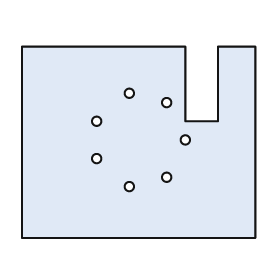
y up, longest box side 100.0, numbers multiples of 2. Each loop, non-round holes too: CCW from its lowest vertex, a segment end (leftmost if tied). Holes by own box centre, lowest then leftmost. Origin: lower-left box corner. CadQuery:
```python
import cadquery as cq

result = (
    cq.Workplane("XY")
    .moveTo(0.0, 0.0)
    .lineTo(100.0, 0.0)
    .lineTo(100.0, 82.0)
    .lineTo(84.0, 82.0)
    .lineTo(84.0, 50.0)
    .lineTo(70.0, 50.0)
    .lineTo(70.0, 82.0)
    .lineTo(0.0, 82.0)
    .close()
    .moveTo(46.0, 22.0)
    .circle(2.0)
    .moveTo(62.0, 26.0)
    .circle(2.0)
    .moveTo(32.0, 34.0)
    .circle(2.0)
    .moveTo(70.0, 42.0)
    .circle(2.0)
    .moveTo(32.0, 50.0)
    .circle(2.0)
    .moveTo(62.0, 58.0)
    .circle(2.0)
    .moveTo(46.0, 62.0)
    .circle(2.0)
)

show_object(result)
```